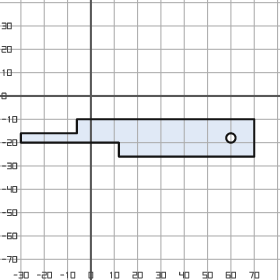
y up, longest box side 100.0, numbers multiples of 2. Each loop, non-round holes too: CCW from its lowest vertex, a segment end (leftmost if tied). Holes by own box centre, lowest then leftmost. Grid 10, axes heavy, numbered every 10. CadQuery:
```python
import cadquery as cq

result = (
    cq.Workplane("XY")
    .moveTo(12.0, -26.0)
    .lineTo(70.0, -26.0)
    .lineTo(70.0, -10.0)
    .lineTo(-6.0, -10.0)
    .lineTo(-6.0, -16.0)
    .lineTo(-30.0, -16.0)
    .lineTo(-30.0, -20.0)
    .lineTo(12.0, -20.0)
    .close()
    .moveTo(60.0, -18.0)
    .circle(2.0)
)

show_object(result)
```